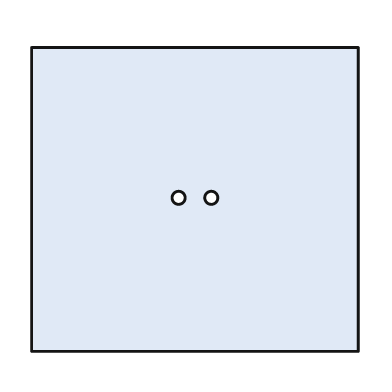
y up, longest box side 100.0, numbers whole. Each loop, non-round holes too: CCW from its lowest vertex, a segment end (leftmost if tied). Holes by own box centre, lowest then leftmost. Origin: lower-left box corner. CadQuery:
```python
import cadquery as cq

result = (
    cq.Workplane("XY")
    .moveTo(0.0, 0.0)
    .lineTo(100.0, 0.0)
    .lineTo(100.0, 93.0)
    .lineTo(0.0, 93.0)
    .close()
    .moveTo(45.0, 47.0)
    .circle(2.0)
    .moveTo(55.0, 47.0)
    .circle(2.0)
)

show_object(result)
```